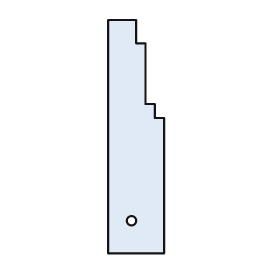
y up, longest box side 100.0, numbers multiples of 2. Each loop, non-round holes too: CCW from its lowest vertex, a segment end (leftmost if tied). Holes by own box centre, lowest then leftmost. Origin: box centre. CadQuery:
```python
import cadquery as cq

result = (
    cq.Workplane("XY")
    .moveTo(-12.0, -50.0)
    .lineTo(12.0, -50.0)
    .lineTo(12.0, 8.0)
    .lineTo(8.0, 8.0)
    .lineTo(8.0, 14.0)
    .lineTo(4.0, 14.0)
    .lineTo(4.0, 40.0)
    .lineTo(0.0, 40.0)
    .lineTo(0.0, 50.0)
    .lineTo(-12.0, 50.0)
    .close()
    .moveTo(-2.0, -36.0)
    .circle(2.0)
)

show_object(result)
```